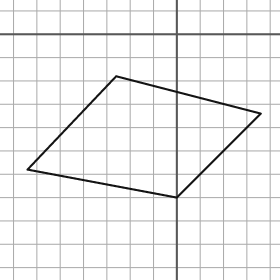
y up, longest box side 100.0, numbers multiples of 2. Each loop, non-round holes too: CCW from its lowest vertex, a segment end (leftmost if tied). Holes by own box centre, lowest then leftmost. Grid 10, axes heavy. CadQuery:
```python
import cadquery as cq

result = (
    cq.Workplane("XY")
    .moveTo(0.0, -70.0)
    .lineTo(36.0, -34.0)
    .lineTo(-26.0, -18.0)
    .lineTo(-64.0, -58.0)
    .close()
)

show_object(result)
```